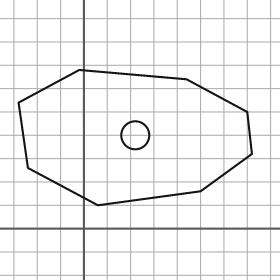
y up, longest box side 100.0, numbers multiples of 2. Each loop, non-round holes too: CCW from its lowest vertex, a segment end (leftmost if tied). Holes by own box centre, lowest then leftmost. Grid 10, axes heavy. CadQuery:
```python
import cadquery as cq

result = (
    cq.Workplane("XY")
    .moveTo(6.0, 10.0)
    .lineTo(50.0, 16.0)
    .lineTo(72.0, 32.0)
    .lineTo(70.0, 50.0)
    .lineTo(44.0, 64.0)
    .lineTo(-2.0, 68.0)
    .lineTo(-28.0, 54.0)
    .lineTo(-24.0, 26.0)
    .close()
    .moveTo(22.0, 40.0)
    .circle(6.0)
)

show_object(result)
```